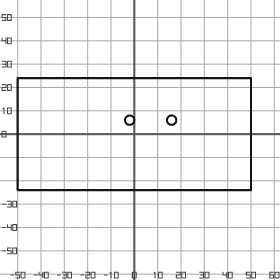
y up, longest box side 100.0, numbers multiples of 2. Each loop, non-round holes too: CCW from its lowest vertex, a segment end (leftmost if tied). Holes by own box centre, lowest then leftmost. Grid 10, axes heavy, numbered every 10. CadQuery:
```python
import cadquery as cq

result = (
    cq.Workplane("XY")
    .moveTo(-50.0, -24.0)
    .lineTo(50.0, -24.0)
    .lineTo(50.0, 24.0)
    .lineTo(-50.0, 24.0)
    .close()
    .moveTo(-2.0, 6.0)
    .circle(2.0)
    .moveTo(16.0, 6.0)
    .circle(2.0)
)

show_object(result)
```